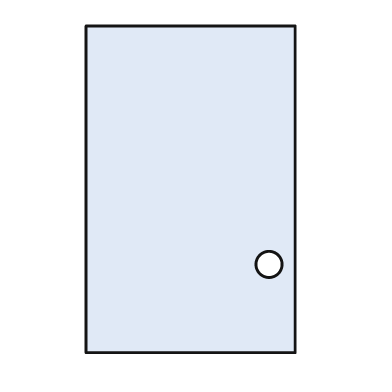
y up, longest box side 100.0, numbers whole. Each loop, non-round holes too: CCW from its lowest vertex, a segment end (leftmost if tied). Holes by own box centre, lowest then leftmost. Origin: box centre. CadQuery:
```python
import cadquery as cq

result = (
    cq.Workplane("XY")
    .moveTo(-32.0, -50.0)
    .lineTo(32.0, -50.0)
    .lineTo(32.0, 50.0)
    .lineTo(-32.0, 50.0)
    .close()
    .moveTo(24.0, -23.0)
    .circle(4.0)
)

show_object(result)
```